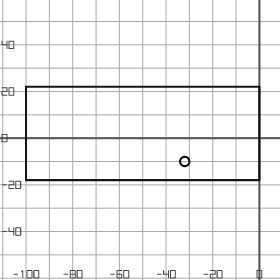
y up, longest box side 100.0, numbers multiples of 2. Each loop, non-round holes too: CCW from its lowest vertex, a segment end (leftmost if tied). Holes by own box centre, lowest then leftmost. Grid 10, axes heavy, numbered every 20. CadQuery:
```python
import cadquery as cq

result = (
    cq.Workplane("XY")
    .moveTo(-100.0, -18.0)
    .lineTo(0.0, -18.0)
    .lineTo(0.0, 22.0)
    .lineTo(-100.0, 22.0)
    .close()
    .moveTo(-32.0, -10.0)
    .circle(2.0)
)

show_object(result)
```